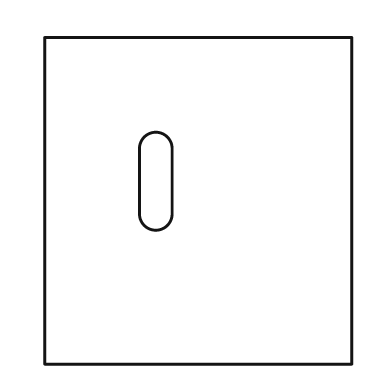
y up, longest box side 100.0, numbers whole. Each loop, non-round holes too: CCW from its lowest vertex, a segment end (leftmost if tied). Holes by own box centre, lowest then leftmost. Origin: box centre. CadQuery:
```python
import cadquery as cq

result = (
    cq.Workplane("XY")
    .moveTo(-47.0, -50.0)
    .lineTo(47.0, -50.0)
    .lineTo(47.0, 50.0)
    .lineTo(-47.0, 50.0)
    .close()
    .moveTo(-18.0, -4.0)
    .threePointArc((-13.0, -9.0), (-8.0, -4.0))
    .lineTo(-8.0, 16.0)
    .threePointArc((-13.0, 21.0), (-18.0, 16.0))
    .close()
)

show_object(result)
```